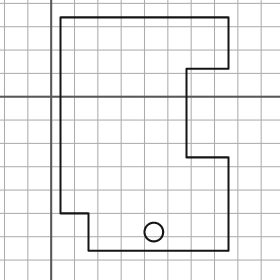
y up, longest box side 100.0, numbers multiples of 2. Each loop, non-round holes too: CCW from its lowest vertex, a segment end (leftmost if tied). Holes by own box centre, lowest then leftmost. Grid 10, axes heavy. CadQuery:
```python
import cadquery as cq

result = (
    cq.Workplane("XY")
    .moveTo(16.0, -66.0)
    .lineTo(76.0, -66.0)
    .lineTo(76.0, -26.0)
    .lineTo(58.0, -26.0)
    .lineTo(58.0, 12.0)
    .lineTo(76.0, 12.0)
    .lineTo(76.0, 34.0)
    .lineTo(4.0, 34.0)
    .lineTo(4.0, -50.0)
    .lineTo(16.0, -50.0)
    .close()
    .moveTo(44.0, -58.0)
    .circle(4.0)
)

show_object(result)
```